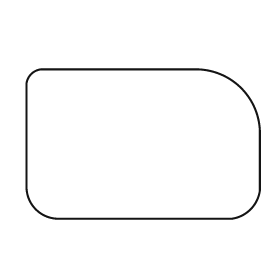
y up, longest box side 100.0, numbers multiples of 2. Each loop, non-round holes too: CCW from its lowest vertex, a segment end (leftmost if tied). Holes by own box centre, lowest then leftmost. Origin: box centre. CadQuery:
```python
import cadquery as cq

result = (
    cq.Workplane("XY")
    .moveTo(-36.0, -32.0)
    .lineTo(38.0, -32.0)
    .threePointArc((46.0, -28.0), (50.0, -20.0))
    .lineTo(50.0, 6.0)
    .threePointArc((42.0, 24.0), (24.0, 32.0))
    .lineTo(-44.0, 32.0)
    .threePointArc((-48.0, 30.0), (-50.0, 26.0))
    .lineTo(-50.0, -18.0)
    .threePointArc((-46.0, -28.0), (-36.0, -32.0))
    .close()
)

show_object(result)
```